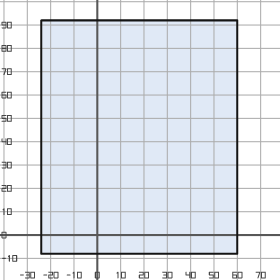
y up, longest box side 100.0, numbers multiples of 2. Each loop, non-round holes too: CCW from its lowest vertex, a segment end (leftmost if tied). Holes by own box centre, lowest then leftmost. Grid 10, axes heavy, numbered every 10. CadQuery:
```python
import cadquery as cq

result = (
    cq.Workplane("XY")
    .moveTo(-24.0, -8.0)
    .lineTo(60.0, -8.0)
    .lineTo(60.0, 92.0)
    .lineTo(-24.0, 92.0)
    .close()
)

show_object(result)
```